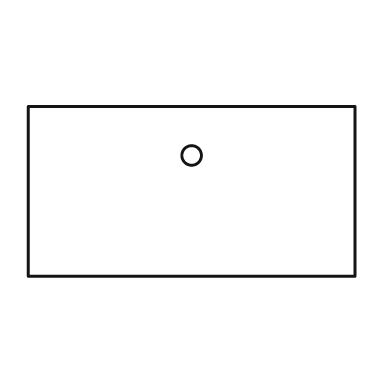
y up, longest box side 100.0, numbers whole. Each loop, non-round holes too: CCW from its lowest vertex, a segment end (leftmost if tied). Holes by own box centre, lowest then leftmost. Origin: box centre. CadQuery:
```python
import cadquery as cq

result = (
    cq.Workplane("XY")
    .moveTo(-50.0, -26.0)
    .lineTo(50.0, -26.0)
    .lineTo(50.0, 26.0)
    .lineTo(-50.0, 26.0)
    .close()
    .moveTo(0.0, 11.0)
    .circle(3.0)
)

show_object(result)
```